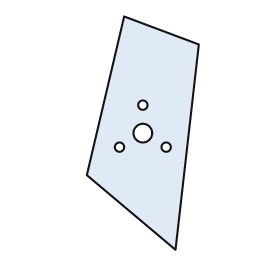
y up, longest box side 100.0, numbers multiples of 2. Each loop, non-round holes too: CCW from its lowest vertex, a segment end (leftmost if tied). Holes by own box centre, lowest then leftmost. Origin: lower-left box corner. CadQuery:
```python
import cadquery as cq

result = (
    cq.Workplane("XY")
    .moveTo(38.0, 0.0)
    .lineTo(48.0, 88.0)
    .lineTo(16.0, 100.0)
    .lineTo(0.0, 32.0)
    .close()
    .moveTo(14.0, 44.0)
    .circle(2.0)
    .moveTo(34.0, 44.0)
    .circle(2.0)
    .moveTo(24.0, 50.0)
    .circle(4.0)
    .moveTo(24.0, 62.0)
    .circle(2.0)
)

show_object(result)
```